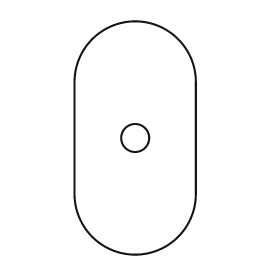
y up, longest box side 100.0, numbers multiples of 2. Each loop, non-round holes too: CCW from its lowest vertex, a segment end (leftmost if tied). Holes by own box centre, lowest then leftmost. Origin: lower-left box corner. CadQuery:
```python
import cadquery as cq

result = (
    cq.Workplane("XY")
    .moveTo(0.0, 26.0)
    .threePointArc((26.0, 0.0), (52.0, 26.0))
    .lineTo(52.0, 74.0)
    .threePointArc((26.0, 100.0), (0.0, 74.0))
    .close()
    .moveTo(26.0, 50.0)
    .circle(6.0)
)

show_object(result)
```